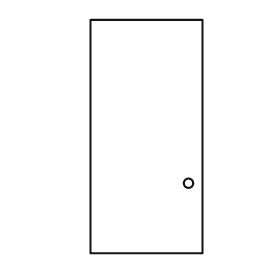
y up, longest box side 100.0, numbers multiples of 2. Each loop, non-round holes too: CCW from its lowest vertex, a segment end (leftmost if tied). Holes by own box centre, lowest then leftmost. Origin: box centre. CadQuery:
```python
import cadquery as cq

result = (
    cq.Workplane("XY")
    .moveTo(-24.0, -50.0)
    .lineTo(24.0, -50.0)
    .lineTo(24.0, 50.0)
    .lineTo(-24.0, 50.0)
    .close()
    .moveTo(18.0, -20.0)
    .circle(2.0)
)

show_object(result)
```